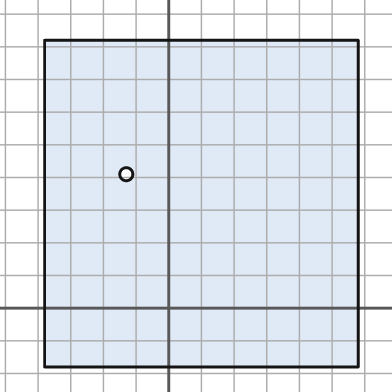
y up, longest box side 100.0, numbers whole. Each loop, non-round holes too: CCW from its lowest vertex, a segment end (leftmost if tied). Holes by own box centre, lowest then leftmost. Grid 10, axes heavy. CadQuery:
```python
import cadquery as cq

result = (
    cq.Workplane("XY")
    .moveTo(-38.0, -18.0)
    .lineTo(58.0, -18.0)
    .lineTo(58.0, 82.0)
    .lineTo(-38.0, 82.0)
    .close()
    .moveTo(-13.0, 41.0)
    .circle(2.0)
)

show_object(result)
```